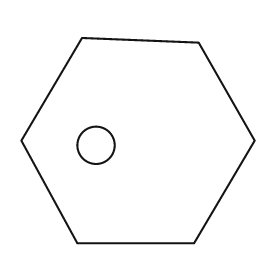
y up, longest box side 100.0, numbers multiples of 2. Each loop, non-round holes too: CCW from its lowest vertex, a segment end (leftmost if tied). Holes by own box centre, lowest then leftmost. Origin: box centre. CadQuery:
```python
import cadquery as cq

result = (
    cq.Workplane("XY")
    .moveTo(-26.0, -44.0)
    .lineTo(24.0, -44.0)
    .lineTo(50.0, 0.0)
    .lineTo(26.0, 42.0)
    .lineTo(-24.0, 44.0)
    .lineTo(-50.0, 0.0)
    .close()
    .moveTo(-18.0, -2.0)
    .circle(8.0)
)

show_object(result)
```